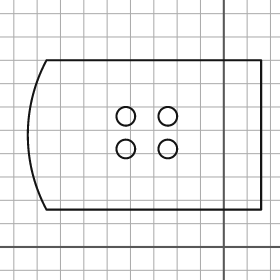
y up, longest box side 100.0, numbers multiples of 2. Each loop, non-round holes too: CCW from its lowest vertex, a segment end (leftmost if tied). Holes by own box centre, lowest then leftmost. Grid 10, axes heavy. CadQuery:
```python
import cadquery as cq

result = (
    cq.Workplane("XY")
    .moveTo(-76.0, 16.0)
    .lineTo(16.0, 16.0)
    .lineTo(16.0, 80.0)
    .lineTo(-76.0, 80.0)
    .threePointArc((-84.0, 48.0), (-76.0, 16.0))
    .close()
    .moveTo(-42.0, 42.0)
    .circle(4.0)
    .moveTo(-24.0, 42.0)
    .circle(4.0)
    .moveTo(-42.0, 56.0)
    .circle(4.0)
    .moveTo(-24.0, 56.0)
    .circle(4.0)
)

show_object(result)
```